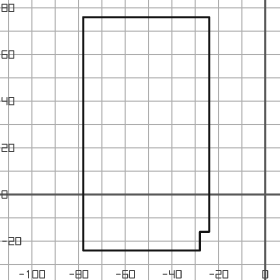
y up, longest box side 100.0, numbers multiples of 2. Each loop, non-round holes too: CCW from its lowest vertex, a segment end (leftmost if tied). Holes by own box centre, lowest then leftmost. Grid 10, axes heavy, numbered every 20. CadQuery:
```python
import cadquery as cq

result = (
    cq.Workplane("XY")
    .moveTo(-78.0, -24.0)
    .lineTo(-28.0, -24.0)
    .lineTo(-28.0, -16.0)
    .lineTo(-24.0, -16.0)
    .lineTo(-24.0, 76.0)
    .lineTo(-78.0, 76.0)
    .close()
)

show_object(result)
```